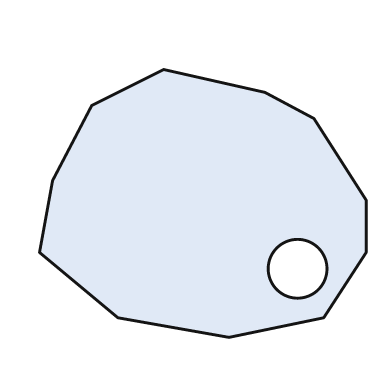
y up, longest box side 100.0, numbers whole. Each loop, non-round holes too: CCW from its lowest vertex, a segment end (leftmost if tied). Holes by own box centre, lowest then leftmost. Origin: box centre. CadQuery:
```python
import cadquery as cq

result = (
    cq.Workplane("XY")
    .moveTo(8.0, -41.0)
    .lineTo(37.0, -35.0)
    .lineTo(50.0, -15.0)
    .lineTo(50.0, 1.0)
    .lineTo(34.0, 26.0)
    .lineTo(19.0, 34.0)
    .lineTo(-12.0, 41.0)
    .lineTo(-34.0, 30.0)
    .lineTo(-46.0, 7.0)
    .lineTo(-50.0, -15.0)
    .lineTo(-26.0, -35.0)
    .close()
    .moveTo(29.0, -20.0)
    .circle(9.0)
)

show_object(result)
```